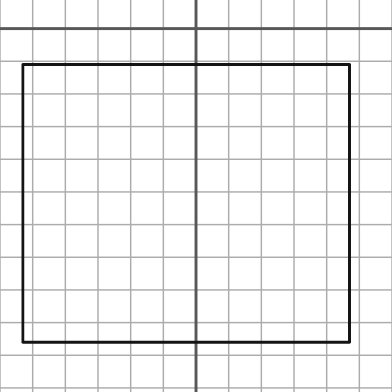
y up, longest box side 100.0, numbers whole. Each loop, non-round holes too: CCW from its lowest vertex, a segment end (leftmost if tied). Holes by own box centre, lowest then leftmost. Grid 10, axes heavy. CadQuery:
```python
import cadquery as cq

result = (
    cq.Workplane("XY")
    .moveTo(-53.0, -96.0)
    .lineTo(47.0, -96.0)
    .lineTo(47.0, -11.0)
    .lineTo(-53.0, -11.0)
    .close()
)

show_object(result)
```